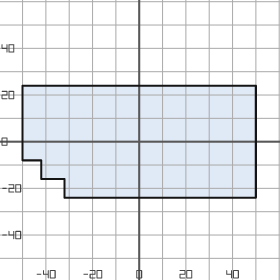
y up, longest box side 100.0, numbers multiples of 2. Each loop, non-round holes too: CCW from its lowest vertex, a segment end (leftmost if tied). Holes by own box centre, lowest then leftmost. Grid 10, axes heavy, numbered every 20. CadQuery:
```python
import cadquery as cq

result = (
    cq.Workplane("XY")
    .moveTo(-32.0, -24.0)
    .lineTo(50.0, -24.0)
    .lineTo(50.0, 24.0)
    .lineTo(-50.0, 24.0)
    .lineTo(-50.0, -8.0)
    .lineTo(-42.0, -8.0)
    .lineTo(-42.0, -16.0)
    .lineTo(-32.0, -16.0)
    .close()
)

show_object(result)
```